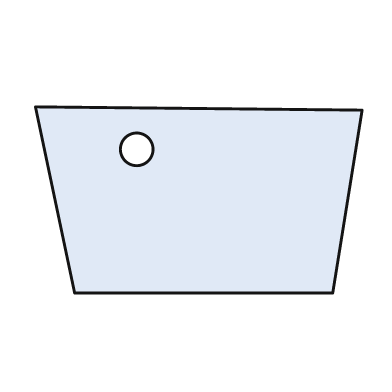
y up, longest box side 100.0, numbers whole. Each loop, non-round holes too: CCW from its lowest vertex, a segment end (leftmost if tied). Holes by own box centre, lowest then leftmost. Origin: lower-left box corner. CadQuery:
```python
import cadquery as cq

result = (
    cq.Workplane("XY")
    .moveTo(12.0, 0.0)
    .lineTo(91.0, 0.0)
    .lineTo(100.0, 56.0)
    .lineTo(0.0, 57.0)
    .close()
    .moveTo(31.0, 44.0)
    .circle(5.0)
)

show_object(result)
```